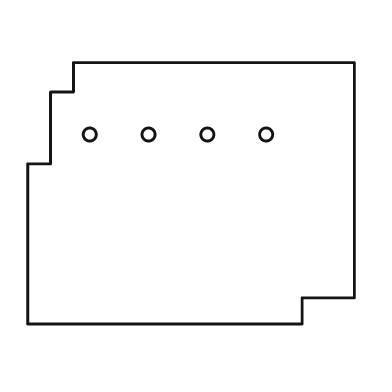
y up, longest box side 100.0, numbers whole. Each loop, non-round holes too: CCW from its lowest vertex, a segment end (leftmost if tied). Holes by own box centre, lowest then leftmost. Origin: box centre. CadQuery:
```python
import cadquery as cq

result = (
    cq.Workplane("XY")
    .moveTo(-50.0, -40.0)
    .lineTo(34.0, -40.0)
    .lineTo(34.0, -32.0)
    .lineTo(50.0, -32.0)
    .lineTo(50.0, 40.0)
    .lineTo(-36.0, 40.0)
    .lineTo(-36.0, 31.0)
    .lineTo(-43.0, 31.0)
    .lineTo(-43.0, 9.0)
    .lineTo(-50.0, 9.0)
    .close()
    .moveTo(-31.0, 18.0)
    .circle(2.0)
    .moveTo(-13.0, 18.0)
    .circle(2.0)
    .moveTo(5.0, 18.0)
    .circle(2.0)
    .moveTo(23.0, 18.0)
    .circle(2.0)
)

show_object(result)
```